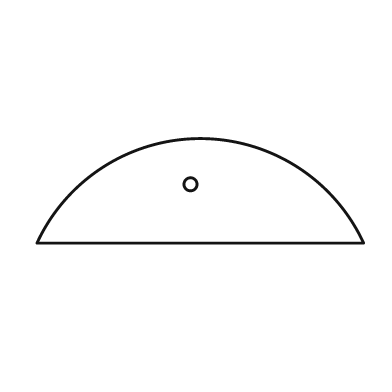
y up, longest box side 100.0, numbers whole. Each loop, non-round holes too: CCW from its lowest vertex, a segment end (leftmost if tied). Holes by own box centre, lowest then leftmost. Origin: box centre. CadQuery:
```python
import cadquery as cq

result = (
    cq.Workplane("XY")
    .moveTo(-50.0, -16.0)
    .lineTo(50.0, -16.0)
    .threePointArc((0.0, 16.0), (-50.0, -16.0))
    .close()
    .moveTo(-3.0, 2.0)
    .circle(2.0)
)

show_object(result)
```